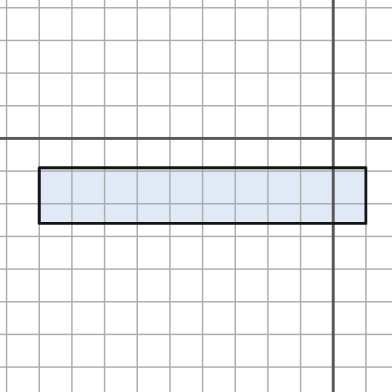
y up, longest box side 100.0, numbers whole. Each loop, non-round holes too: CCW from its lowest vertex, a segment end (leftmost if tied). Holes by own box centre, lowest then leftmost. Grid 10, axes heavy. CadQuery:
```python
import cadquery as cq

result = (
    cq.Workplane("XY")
    .moveTo(-90.0, -26.0)
    .lineTo(10.0, -26.0)
    .lineTo(10.0, -9.0)
    .lineTo(-90.0, -9.0)
    .close()
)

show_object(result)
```